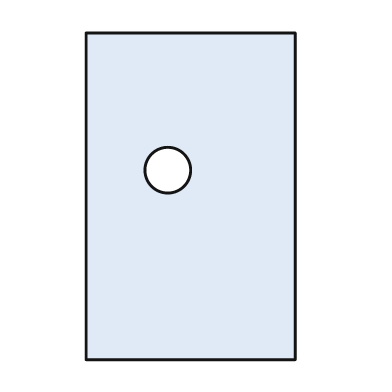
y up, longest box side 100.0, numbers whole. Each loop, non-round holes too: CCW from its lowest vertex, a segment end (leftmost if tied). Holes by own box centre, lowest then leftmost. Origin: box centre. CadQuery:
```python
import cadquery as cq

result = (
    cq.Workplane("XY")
    .moveTo(-32.0, -50.0)
    .lineTo(32.0, -50.0)
    .lineTo(32.0, 50.0)
    .lineTo(-32.0, 50.0)
    .close()
    .moveTo(-7.0, 8.0)
    .circle(7.0)
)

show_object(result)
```